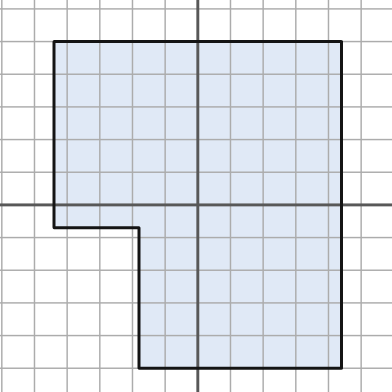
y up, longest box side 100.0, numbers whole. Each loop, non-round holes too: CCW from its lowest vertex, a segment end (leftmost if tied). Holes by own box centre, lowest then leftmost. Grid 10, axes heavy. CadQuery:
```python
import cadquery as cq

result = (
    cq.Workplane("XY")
    .moveTo(-18.0, -50.0)
    .lineTo(44.0, -50.0)
    .lineTo(44.0, 50.0)
    .lineTo(-44.0, 50.0)
    .lineTo(-44.0, -7.0)
    .lineTo(-18.0, -7.0)
    .close()
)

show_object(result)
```